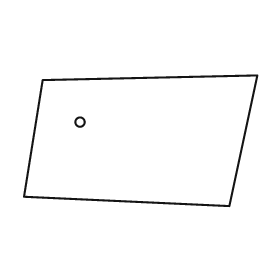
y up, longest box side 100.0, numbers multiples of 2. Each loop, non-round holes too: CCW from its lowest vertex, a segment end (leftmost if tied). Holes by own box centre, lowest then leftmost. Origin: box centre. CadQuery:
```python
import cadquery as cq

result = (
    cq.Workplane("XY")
    .moveTo(38.0, -28.0)
    .lineTo(50.0, 28.0)
    .lineTo(-42.0, 26.0)
    .lineTo(-50.0, -24.0)
    .close()
    .moveTo(-26.0, 8.0)
    .circle(2.0)
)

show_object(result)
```